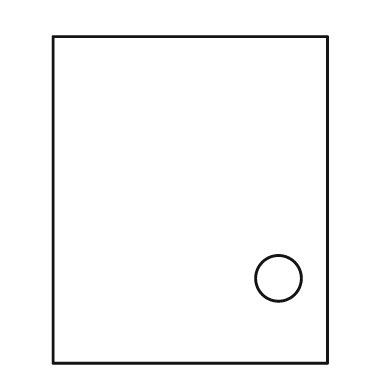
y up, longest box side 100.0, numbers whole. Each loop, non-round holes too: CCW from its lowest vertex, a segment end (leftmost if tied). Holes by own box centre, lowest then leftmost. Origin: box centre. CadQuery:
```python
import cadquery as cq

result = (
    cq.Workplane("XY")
    .moveTo(-42.0, -50.0)
    .lineTo(42.0, -50.0)
    .lineTo(42.0, 50.0)
    .lineTo(-42.0, 50.0)
    .close()
    .moveTo(27.0, -24.0)
    .circle(7.0)
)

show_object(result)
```